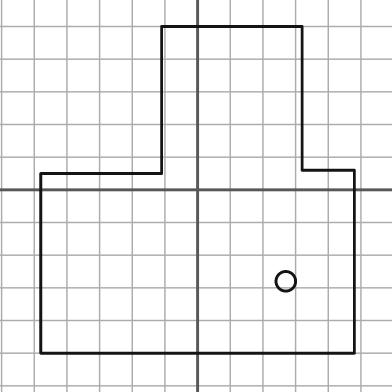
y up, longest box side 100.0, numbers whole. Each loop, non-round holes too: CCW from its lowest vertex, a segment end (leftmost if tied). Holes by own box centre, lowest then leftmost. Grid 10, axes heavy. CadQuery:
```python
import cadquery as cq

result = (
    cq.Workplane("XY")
    .moveTo(-48.0, -50.0)
    .lineTo(48.0, -50.0)
    .lineTo(48.0, 6.0)
    .lineTo(32.0, 6.0)
    .lineTo(32.0, 50.0)
    .lineTo(-11.0, 50.0)
    .lineTo(-11.0, 5.0)
    .lineTo(-48.0, 5.0)
    .close()
    .moveTo(27.0, -28.0)
    .circle(3.0)
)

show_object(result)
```